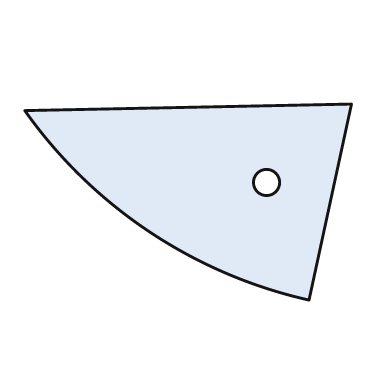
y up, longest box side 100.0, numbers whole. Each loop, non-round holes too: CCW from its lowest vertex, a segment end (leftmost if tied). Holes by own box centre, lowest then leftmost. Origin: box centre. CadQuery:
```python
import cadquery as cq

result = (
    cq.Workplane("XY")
    .moveTo(37.0, -30.0)
    .lineTo(50.0, 30.0)
    .lineTo(-50.0, 28.0)
    .threePointArc((-12.0, -9.0), (37.0, -30.0))
    .close()
    .moveTo(24.0, 6.0)
    .circle(4.0)
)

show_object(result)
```